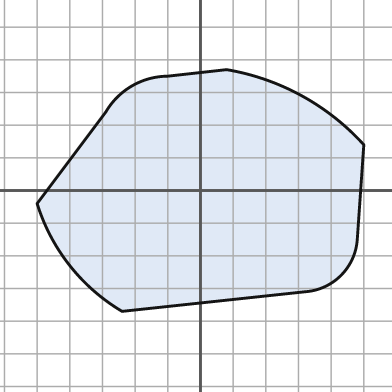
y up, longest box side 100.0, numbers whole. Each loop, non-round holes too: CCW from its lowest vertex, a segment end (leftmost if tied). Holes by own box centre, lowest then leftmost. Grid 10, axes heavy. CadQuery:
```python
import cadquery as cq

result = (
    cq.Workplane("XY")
    .moveTo(-24.0, -37.0)
    .lineTo(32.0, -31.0)
    .threePointArc((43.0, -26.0), (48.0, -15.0))
    .lineTo(50.0, 14.0)
    .threePointArc((31.0, 29.0), (8.0, 37.0))
    .lineTo(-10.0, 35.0)
    .threePointArc((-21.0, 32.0), (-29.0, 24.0))
    .lineTo(-50.0, -4.0)
    .threePointArc((-40.0, -23.0), (-24.0, -37.0))
    .close()
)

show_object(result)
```